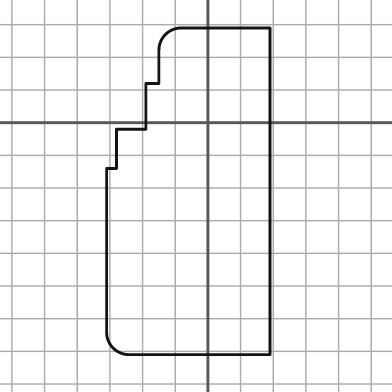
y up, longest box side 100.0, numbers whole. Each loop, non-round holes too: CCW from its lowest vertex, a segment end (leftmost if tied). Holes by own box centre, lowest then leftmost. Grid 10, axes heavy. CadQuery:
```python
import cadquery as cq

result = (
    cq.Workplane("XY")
    .moveTo(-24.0, -71.0)
    .lineTo(19.0, -71.0)
    .lineTo(19.0, 29.0)
    .lineTo(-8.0, 29.0)
    .threePointArc((-13.0, 27.0), (-15.0, 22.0))
    .lineTo(-15.0, 12.0)
    .lineTo(-19.0, 12.0)
    .lineTo(-19.0, -2.0)
    .lineTo(-28.0, -2.0)
    .lineTo(-28.0, -14.0)
    .lineTo(-31.0, -14.0)
    .lineTo(-31.0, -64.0)
    .threePointArc((-29.0, -69.0), (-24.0, -71.0))
    .close()
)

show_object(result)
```